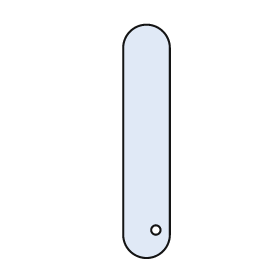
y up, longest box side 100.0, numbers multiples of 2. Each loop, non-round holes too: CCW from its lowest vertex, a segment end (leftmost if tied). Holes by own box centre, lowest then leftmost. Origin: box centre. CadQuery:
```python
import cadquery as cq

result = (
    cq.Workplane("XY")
    .moveTo(-10.0, -40.0)
    .threePointArc((0.0, -50.0), (10.0, -40.0))
    .lineTo(10.0, 40.0)
    .threePointArc((0.0, 50.0), (-10.0, 40.0))
    .close()
    .moveTo(4.0, -38.0)
    .circle(2.0)
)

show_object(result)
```